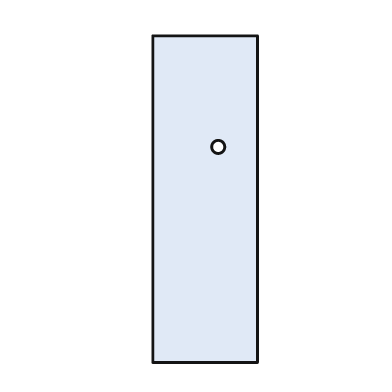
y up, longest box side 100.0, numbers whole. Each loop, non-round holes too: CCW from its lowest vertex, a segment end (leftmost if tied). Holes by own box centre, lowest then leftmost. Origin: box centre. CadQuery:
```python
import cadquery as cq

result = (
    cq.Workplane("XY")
    .moveTo(-16.0, -50.0)
    .lineTo(16.0, -50.0)
    .lineTo(16.0, 50.0)
    .lineTo(-16.0, 50.0)
    .close()
    .moveTo(4.0, 16.0)
    .circle(2.0)
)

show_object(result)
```